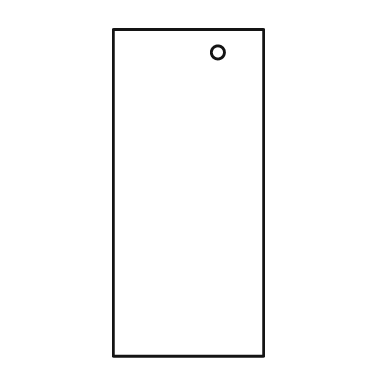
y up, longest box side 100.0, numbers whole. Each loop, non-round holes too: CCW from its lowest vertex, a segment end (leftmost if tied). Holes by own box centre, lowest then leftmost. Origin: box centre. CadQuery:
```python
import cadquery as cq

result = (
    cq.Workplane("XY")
    .moveTo(-23.0, -50.0)
    .lineTo(23.0, -50.0)
    .lineTo(23.0, 50.0)
    .lineTo(-23.0, 50.0)
    .close()
    .moveTo(9.0, 43.0)
    .circle(2.0)
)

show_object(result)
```